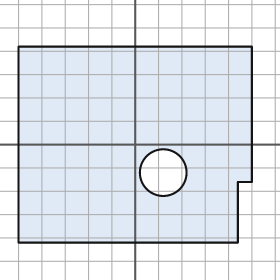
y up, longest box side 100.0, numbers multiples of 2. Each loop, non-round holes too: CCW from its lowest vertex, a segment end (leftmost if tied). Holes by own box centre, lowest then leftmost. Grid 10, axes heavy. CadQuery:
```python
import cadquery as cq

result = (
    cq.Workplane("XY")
    .moveTo(-50.0, -42.0)
    .lineTo(44.0, -42.0)
    .lineTo(44.0, -16.0)
    .lineTo(50.0, -16.0)
    .lineTo(50.0, 42.0)
    .lineTo(-50.0, 42.0)
    .close()
    .moveTo(12.0, -12.0)
    .circle(10.0)
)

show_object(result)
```